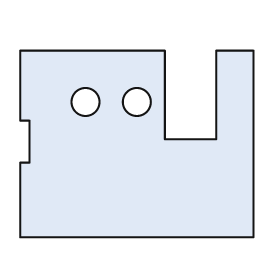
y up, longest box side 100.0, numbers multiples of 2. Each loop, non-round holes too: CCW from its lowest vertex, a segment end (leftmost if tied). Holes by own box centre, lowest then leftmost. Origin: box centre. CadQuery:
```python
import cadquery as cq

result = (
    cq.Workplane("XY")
    .moveTo(-50.0, -40.0)
    .lineTo(50.0, -40.0)
    .lineTo(50.0, 40.0)
    .lineTo(34.0, 40.0)
    .lineTo(34.0, 2.0)
    .lineTo(12.0, 2.0)
    .lineTo(12.0, 40.0)
    .lineTo(-50.0, 40.0)
    .lineTo(-50.0, 10.0)
    .lineTo(-46.0, 10.0)
    .lineTo(-46.0, -8.0)
    .lineTo(-50.0, -8.0)
    .close()
    .moveTo(-22.0, 18.0)
    .circle(6.0)
    .moveTo(0.0, 18.0)
    .circle(6.0)
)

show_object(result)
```